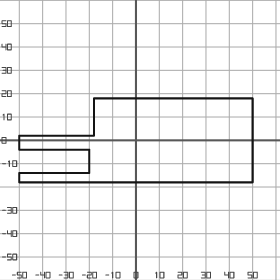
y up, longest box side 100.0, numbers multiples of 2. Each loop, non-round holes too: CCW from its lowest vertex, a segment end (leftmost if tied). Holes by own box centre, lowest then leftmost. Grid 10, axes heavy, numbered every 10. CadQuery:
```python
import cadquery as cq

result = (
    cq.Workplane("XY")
    .moveTo(-50.0, -18.0)
    .lineTo(50.0, -18.0)
    .lineTo(50.0, 18.0)
    .lineTo(-18.0, 18.0)
    .lineTo(-18.0, 2.0)
    .lineTo(-50.0, 2.0)
    .lineTo(-50.0, -4.0)
    .lineTo(-20.0, -4.0)
    .lineTo(-20.0, -14.0)
    .lineTo(-50.0, -14.0)
    .close()
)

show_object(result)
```